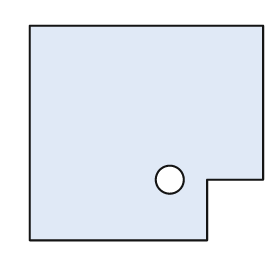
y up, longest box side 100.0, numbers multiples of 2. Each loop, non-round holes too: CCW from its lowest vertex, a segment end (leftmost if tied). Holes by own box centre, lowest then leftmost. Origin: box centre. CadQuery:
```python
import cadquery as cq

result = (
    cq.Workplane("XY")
    .moveTo(-50.0, -46.0)
    .lineTo(26.0, -46.0)
    .lineTo(26.0, -20.0)
    .lineTo(50.0, -20.0)
    .lineTo(50.0, 46.0)
    .lineTo(-50.0, 46.0)
    .close()
    .moveTo(10.0, -20.0)
    .circle(6.0)
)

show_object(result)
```